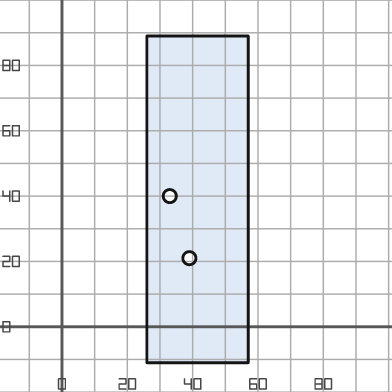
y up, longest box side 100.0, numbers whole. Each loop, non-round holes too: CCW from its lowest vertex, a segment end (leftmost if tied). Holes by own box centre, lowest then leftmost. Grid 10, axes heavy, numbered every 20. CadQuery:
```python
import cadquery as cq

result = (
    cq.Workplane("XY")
    .moveTo(26.0, -11.0)
    .lineTo(57.0, -11.0)
    .lineTo(57.0, 89.0)
    .lineTo(26.0, 89.0)
    .close()
    .moveTo(39.0, 21.0)
    .circle(2.0)
    .moveTo(33.0, 40.0)
    .circle(2.0)
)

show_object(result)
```